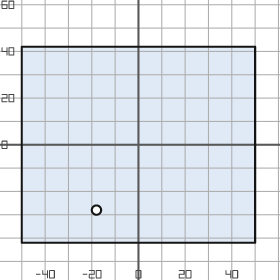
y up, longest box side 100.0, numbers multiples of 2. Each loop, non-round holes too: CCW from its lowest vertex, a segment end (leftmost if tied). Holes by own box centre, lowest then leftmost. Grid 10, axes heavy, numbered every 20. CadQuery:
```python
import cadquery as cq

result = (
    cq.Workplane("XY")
    .moveTo(-50.0, -42.0)
    .lineTo(50.0, -42.0)
    .lineTo(50.0, 42.0)
    .lineTo(-50.0, 42.0)
    .close()
    .moveTo(-18.0, -28.0)
    .circle(2.0)
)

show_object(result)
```